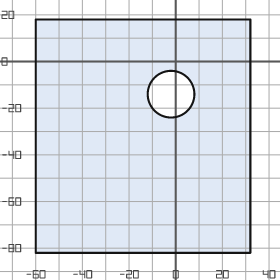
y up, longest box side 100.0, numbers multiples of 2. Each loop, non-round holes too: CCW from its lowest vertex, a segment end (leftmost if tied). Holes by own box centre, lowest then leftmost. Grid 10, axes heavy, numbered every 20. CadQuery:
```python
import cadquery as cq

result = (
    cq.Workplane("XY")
    .moveTo(-60.0, -82.0)
    .lineTo(32.0, -82.0)
    .lineTo(32.0, 18.0)
    .lineTo(-60.0, 18.0)
    .close()
    .moveTo(-2.0, -14.0)
    .circle(10.0)
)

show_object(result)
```